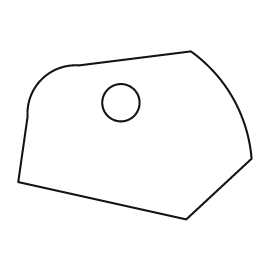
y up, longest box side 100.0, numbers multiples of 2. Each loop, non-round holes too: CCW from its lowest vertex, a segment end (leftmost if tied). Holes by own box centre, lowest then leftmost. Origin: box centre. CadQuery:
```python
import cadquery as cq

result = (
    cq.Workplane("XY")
    .moveTo(22.0, -36.0)
    .lineTo(50.0, -10.0)
    .threePointArc((42.0, 16.0), (24.0, 36.0))
    .lineTo(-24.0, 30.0)
    .threePointArc((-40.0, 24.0), (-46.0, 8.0))
    .lineTo(-50.0, -20.0)
    .close()
    .moveTo(-6.0, 14.0)
    .circle(8.0)
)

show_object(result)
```